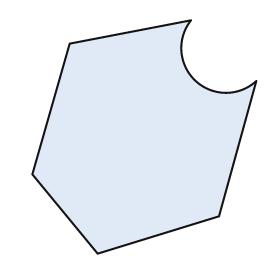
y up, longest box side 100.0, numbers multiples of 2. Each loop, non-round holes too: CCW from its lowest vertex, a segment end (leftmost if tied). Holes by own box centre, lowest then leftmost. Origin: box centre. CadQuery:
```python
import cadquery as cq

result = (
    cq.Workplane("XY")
    .moveTo(-20.0, -50.0)
    .lineTo(32.0, -34.0)
    .lineTo(48.0, 24.0)
    .threePointArc((22.0, 24.0), (20.0, 50.0))
    .lineTo(-32.0, 40.0)
    .lineTo(-48.0, -16.0)
    .close()
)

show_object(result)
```